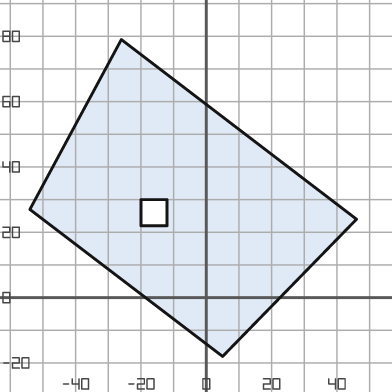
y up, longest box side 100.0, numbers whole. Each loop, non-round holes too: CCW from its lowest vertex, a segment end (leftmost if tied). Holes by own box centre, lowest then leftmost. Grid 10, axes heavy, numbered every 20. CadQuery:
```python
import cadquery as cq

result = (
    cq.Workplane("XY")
    .moveTo(5.0, -18.0)
    .lineTo(46.0, 24.0)
    .lineTo(-26.0, 79.0)
    .lineTo(-54.0, 27.0)
    .close()
    .moveTo(-20.0, 22.0)
    .lineTo(-12.0, 22.0)
    .lineTo(-12.0, 30.0)
    .lineTo(-20.0, 30.0)
    .close()
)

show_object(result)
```